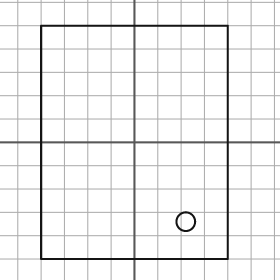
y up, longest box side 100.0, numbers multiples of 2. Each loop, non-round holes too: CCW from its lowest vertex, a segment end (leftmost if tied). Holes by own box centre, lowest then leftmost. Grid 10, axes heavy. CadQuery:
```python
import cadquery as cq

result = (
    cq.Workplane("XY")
    .moveTo(-40.0, -50.0)
    .lineTo(40.0, -50.0)
    .lineTo(40.0, 50.0)
    .lineTo(-40.0, 50.0)
    .close()
    .moveTo(22.0, -34.0)
    .circle(4.0)
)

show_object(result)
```